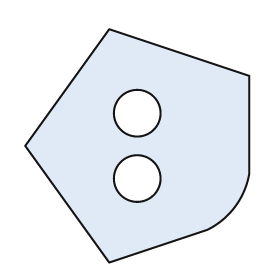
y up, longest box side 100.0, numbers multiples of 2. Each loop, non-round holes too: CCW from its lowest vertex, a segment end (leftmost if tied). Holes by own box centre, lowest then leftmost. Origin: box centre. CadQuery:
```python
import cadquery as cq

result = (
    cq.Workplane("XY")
    .moveTo(-12.0, -50.0)
    .lineTo(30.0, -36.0)
    .threePointArc((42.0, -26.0), (48.0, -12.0))
    .lineTo(48.0, 30.0)
    .lineTo(-12.0, 50.0)
    .lineTo(-48.0, 0.0)
    .close()
    .moveTo(0.0, -14.0)
    .circle(10.0)
    .moveTo(0.0, 14.0)
    .circle(10.0)
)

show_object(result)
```